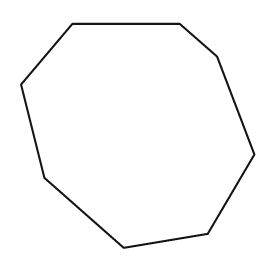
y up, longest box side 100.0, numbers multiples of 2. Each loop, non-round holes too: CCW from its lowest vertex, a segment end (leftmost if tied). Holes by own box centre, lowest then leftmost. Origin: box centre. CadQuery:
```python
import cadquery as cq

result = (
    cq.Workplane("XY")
    .moveTo(-6.0, -48.0)
    .lineTo(30.0, -42.0)
    .lineTo(50.0, -8.0)
    .lineTo(34.0, 34.0)
    .lineTo(18.0, 48.0)
    .lineTo(-28.0, 48.0)
    .lineTo(-50.0, 22.0)
    .lineTo(-40.0, -18.0)
    .close()
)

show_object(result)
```